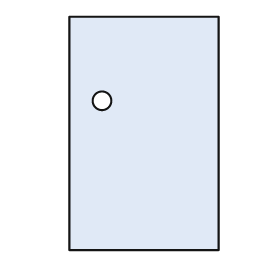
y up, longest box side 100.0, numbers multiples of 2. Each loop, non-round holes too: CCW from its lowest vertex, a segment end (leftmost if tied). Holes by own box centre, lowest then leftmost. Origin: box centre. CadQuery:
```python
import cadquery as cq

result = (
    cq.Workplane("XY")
    .moveTo(-32.0, -50.0)
    .lineTo(32.0, -50.0)
    .lineTo(32.0, 50.0)
    .lineTo(-32.0, 50.0)
    .close()
    .moveTo(-18.0, 14.0)
    .circle(4.0)
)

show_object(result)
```